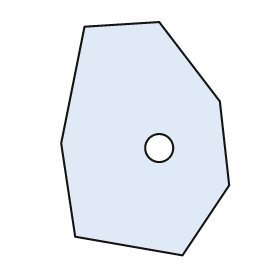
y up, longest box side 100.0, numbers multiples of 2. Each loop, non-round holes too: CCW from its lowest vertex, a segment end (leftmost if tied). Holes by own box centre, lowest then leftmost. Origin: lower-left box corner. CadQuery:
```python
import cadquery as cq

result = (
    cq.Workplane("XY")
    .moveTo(52.0, 0.0)
    .lineTo(72.0, 30.0)
    .lineTo(68.0, 66.0)
    .lineTo(42.0, 100.0)
    .lineTo(10.0, 98.0)
    .lineTo(0.0, 48.0)
    .lineTo(6.0, 8.0)
    .close()
    .moveTo(42.0, 46.0)
    .circle(6.0)
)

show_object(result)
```